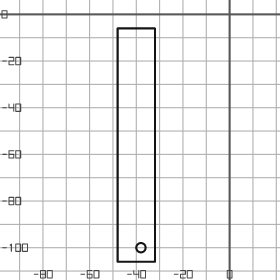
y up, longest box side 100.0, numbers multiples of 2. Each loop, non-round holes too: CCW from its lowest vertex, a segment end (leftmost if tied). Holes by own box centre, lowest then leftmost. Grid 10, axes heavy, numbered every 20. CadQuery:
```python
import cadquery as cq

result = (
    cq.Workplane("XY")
    .moveTo(-48.0, -106.0)
    .lineTo(-32.0, -106.0)
    .lineTo(-32.0, -6.0)
    .lineTo(-48.0, -6.0)
    .close()
    .moveTo(-38.0, -100.0)
    .circle(2.0)
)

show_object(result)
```